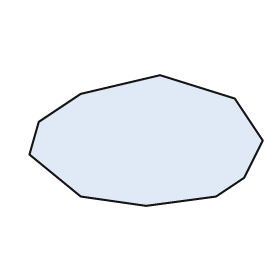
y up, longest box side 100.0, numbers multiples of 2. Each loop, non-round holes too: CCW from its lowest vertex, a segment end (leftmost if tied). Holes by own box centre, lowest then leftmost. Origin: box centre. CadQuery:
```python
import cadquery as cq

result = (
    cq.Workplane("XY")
    .moveTo(0.0, -28.0)
    .lineTo(30.0, -24.0)
    .lineTo(42.0, -16.0)
    .lineTo(50.0, 0.0)
    .lineTo(38.0, 18.0)
    .lineTo(6.0, 28.0)
    .lineTo(-28.0, 20.0)
    .lineTo(-46.0, 8.0)
    .lineTo(-50.0, -6.0)
    .lineTo(-28.0, -24.0)
    .close()
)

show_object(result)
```